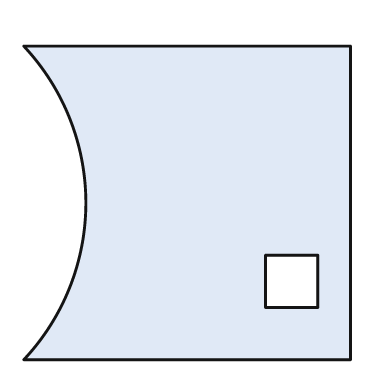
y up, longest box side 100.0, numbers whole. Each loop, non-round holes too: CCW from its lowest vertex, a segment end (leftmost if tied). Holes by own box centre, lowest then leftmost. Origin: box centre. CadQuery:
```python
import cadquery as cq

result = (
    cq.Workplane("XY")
    .moveTo(-50.0, -48.0)
    .lineTo(50.0, -48.0)
    .lineTo(50.0, 48.0)
    .lineTo(-50.0, 48.0)
    .threePointArc((-31.0, 0.0), (-50.0, -48.0))
    .close()
    .moveTo(24.0, -32.0)
    .lineTo(40.0, -32.0)
    .lineTo(40.0, -16.0)
    .lineTo(24.0, -16.0)
    .close()
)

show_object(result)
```